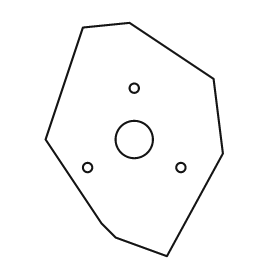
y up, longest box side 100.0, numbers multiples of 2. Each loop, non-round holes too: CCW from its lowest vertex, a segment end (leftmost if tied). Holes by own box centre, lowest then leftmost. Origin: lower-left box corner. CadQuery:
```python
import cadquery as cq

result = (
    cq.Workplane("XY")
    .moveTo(52.0, 0.0)
    .lineTo(76.0, 44.0)
    .lineTo(72.0, 76.0)
    .lineTo(36.0, 100.0)
    .lineTo(16.0, 98.0)
    .lineTo(0.0, 50.0)
    .lineTo(24.0, 14.0)
    .lineTo(30.0, 8.0)
    .close()
    .moveTo(18.0, 38.0)
    .circle(2.0)
    .moveTo(58.0, 38.0)
    .circle(2.0)
    .moveTo(38.0, 50.0)
    .circle(8.0)
    .moveTo(38.0, 72.0)
    .circle(2.0)
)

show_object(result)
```